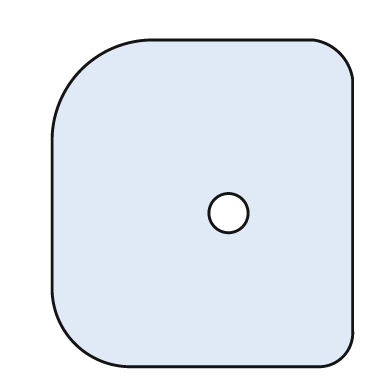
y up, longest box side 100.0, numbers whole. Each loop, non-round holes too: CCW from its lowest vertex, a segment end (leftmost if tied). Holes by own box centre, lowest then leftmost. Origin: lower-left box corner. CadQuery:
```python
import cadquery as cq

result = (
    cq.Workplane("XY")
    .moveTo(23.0, 0.0)
    .lineTo(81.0, 0.0)
    .threePointArc((89.0, 3.0), (92.0, 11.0))
    .lineTo(92.0, 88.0)
    .threePointArc((88.0, 96.0), (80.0, 100.0))
    .lineTo(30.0, 100.0)
    .threePointArc((9.0, 91.0), (0.0, 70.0))
    .lineTo(0.0, 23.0)
    .threePointArc((7.0, 7.0), (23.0, 0.0))
    .close()
    .moveTo(54.0, 47.0)
    .circle(6.0)
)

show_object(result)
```